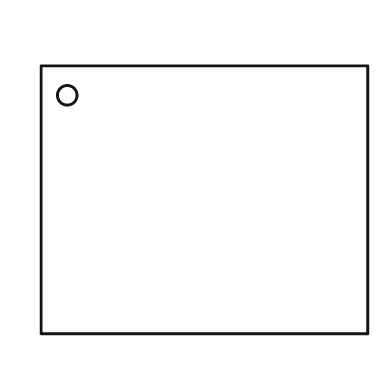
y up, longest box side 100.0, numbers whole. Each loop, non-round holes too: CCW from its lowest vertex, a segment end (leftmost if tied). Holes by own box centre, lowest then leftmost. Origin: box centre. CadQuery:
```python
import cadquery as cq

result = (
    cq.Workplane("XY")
    .moveTo(-50.0, -41.0)
    .lineTo(50.0, -41.0)
    .lineTo(50.0, 41.0)
    .lineTo(-50.0, 41.0)
    .close()
    .moveTo(-42.0, 32.0)
    .circle(3.0)
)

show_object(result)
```